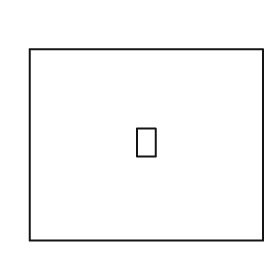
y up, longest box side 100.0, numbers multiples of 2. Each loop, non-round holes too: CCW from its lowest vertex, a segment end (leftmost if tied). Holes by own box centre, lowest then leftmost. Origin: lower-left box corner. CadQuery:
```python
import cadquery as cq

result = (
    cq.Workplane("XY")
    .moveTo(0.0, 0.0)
    .lineTo(100.0, 0.0)
    .lineTo(100.0, 82.0)
    .lineTo(0.0, 82.0)
    .close()
    .moveTo(46.0, 36.0)
    .lineTo(54.0, 36.0)
    .lineTo(54.0, 48.0)
    .lineTo(46.0, 48.0)
    .close()
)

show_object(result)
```